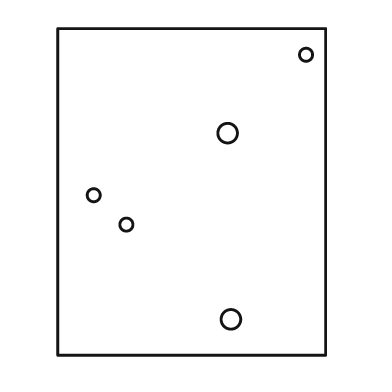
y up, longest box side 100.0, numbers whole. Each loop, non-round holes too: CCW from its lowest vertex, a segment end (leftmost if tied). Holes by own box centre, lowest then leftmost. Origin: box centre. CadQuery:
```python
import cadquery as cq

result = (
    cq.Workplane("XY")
    .moveTo(-41.0, -50.0)
    .lineTo(41.0, -50.0)
    .lineTo(41.0, 50.0)
    .lineTo(-41.0, 50.0)
    .close()
    .moveTo(12.0, -39.0)
    .circle(3.0)
    .moveTo(-20.0, -10.0)
    .circle(2.0)
    .moveTo(-30.0, -1.0)
    .circle(2.0)
    .moveTo(11.0, 18.0)
    .circle(3.0)
    .moveTo(35.0, 42.0)
    .circle(2.0)
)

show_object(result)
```